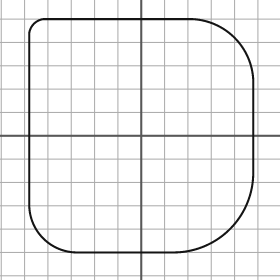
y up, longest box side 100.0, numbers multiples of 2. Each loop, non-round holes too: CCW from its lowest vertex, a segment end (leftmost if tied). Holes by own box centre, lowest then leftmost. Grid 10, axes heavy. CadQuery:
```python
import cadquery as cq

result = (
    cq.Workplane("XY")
    .moveTo(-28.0, -50.0)
    .lineTo(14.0, -50.0)
    .threePointArc((38.0, -40.0), (48.0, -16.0))
    .lineTo(48.0, 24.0)
    .threePointArc((40.0, 42.0), (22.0, 50.0))
    .lineTo(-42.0, 50.0)
    .threePointArc((-46.0, 48.0), (-48.0, 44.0))
    .lineTo(-48.0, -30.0)
    .threePointArc((-42.0, -44.0), (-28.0, -50.0))
    .close()
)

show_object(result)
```